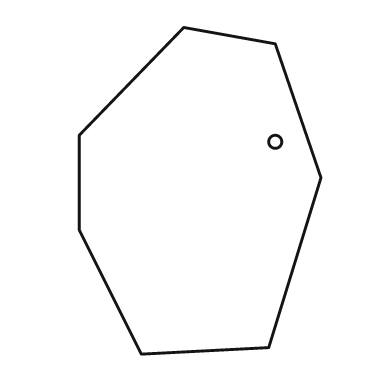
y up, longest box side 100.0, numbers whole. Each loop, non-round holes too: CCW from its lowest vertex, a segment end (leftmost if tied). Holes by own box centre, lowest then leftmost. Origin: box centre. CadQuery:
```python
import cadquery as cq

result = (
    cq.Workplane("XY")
    .moveTo(-18.0, -50.0)
    .lineTo(21.0, -48.0)
    .lineTo(37.0, 4.0)
    .lineTo(23.0, 45.0)
    .lineTo(-5.0, 50.0)
    .lineTo(-37.0, 17.0)
    .lineTo(-37.0, -12.0)
    .close()
    .moveTo(23.0, 15.0)
    .circle(2.0)
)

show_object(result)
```